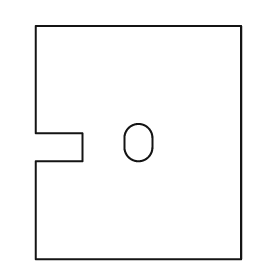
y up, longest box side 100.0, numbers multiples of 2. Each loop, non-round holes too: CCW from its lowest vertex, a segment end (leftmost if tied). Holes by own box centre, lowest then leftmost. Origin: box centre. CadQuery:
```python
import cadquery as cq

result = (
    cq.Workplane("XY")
    .moveTo(-44.0, -50.0)
    .lineTo(44.0, -50.0)
    .lineTo(44.0, 50.0)
    .lineTo(-44.0, 50.0)
    .lineTo(-44.0, 4.0)
    .lineTo(-24.0, 4.0)
    .lineTo(-24.0, -8.0)
    .lineTo(-44.0, -8.0)
    .close()
    .moveTo(-6.0, -2.0)
    .threePointArc((0.0, -8.0), (6.0, -2.0))
    .lineTo(6.0, 2.0)
    .threePointArc((0.0, 8.0), (-6.0, 2.0))
    .close()
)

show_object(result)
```